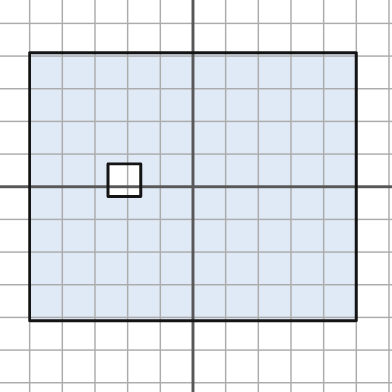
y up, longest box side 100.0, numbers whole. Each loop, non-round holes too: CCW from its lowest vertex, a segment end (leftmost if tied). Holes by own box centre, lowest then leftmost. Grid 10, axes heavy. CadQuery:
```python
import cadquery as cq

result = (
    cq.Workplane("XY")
    .moveTo(-50.0, -41.0)
    .lineTo(50.0, -41.0)
    .lineTo(50.0, 41.0)
    .lineTo(-50.0, 41.0)
    .close()
    .moveTo(-26.0, -3.0)
    .lineTo(-16.0, -3.0)
    .lineTo(-16.0, 7.0)
    .lineTo(-26.0, 7.0)
    .close()
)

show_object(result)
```